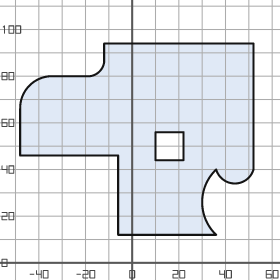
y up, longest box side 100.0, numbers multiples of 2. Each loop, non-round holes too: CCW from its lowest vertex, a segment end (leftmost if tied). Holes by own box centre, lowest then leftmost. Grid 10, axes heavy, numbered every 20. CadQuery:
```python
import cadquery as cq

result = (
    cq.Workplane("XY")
    .moveTo(-6.0, 12.0)
    .lineTo(36.0, 12.0)
    .threePointArc((30.0, 26.0), (36.0, 40.0))
    .threePointArc((44.0, 34.0), (52.0, 40.0))
    .lineTo(52.0, 94.0)
    .lineTo(-12.0, 94.0)
    .lineTo(-12.0, 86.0)
    .threePointArc((-14.0, 82.0), (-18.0, 80.0))
    .lineTo(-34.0, 80.0)
    .threePointArc((-44.0, 76.0), (-48.0, 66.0))
    .lineTo(-48.0, 46.0)
    .lineTo(-6.0, 46.0)
    .close()
    .moveTo(10.0, 44.0)
    .lineTo(22.0, 44.0)
    .lineTo(22.0, 56.0)
    .lineTo(10.0, 56.0)
    .close()
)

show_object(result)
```